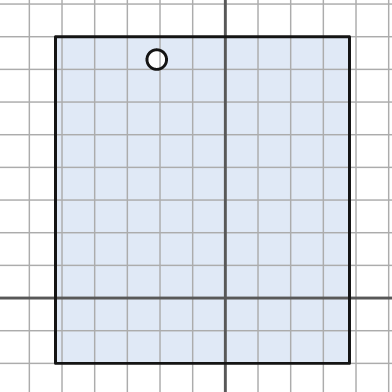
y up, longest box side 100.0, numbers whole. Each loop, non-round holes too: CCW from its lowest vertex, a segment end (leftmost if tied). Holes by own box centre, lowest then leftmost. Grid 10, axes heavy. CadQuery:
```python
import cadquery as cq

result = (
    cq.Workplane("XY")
    .moveTo(-52.0, -20.0)
    .lineTo(38.0, -20.0)
    .lineTo(38.0, 80.0)
    .lineTo(-52.0, 80.0)
    .close()
    .moveTo(-21.0, 73.0)
    .circle(3.0)
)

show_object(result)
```